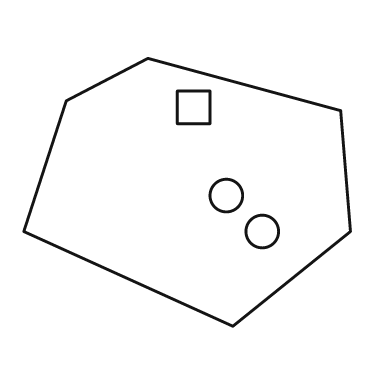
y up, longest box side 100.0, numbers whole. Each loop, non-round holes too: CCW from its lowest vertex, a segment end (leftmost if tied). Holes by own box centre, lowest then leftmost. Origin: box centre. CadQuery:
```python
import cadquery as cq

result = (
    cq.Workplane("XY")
    .moveTo(14.0, -41.0)
    .lineTo(50.0, -12.0)
    .lineTo(47.0, 25.0)
    .lineTo(-12.0, 41.0)
    .lineTo(-37.0, 28.0)
    .lineTo(-50.0, -12.0)
    .close()
    .moveTo(23.0, -12.0)
    .circle(5.0)
    .moveTo(12.0, -1.0)
    .circle(5.0)
    .moveTo(-3.0, 21.0)
    .lineTo(7.0, 21.0)
    .lineTo(7.0, 31.0)
    .lineTo(-3.0, 31.0)
    .close()
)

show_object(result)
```